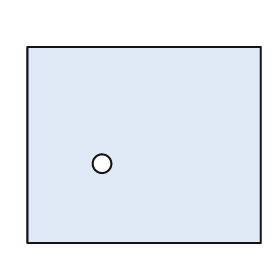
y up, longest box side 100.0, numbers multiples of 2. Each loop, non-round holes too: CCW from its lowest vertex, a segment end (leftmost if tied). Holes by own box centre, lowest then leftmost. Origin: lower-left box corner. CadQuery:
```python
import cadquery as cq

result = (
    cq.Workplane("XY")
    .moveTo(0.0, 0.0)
    .lineTo(100.0, 0.0)
    .lineTo(100.0, 84.0)
    .lineTo(0.0, 84.0)
    .close()
    .moveTo(32.0, 34.0)
    .circle(4.0)
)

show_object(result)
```